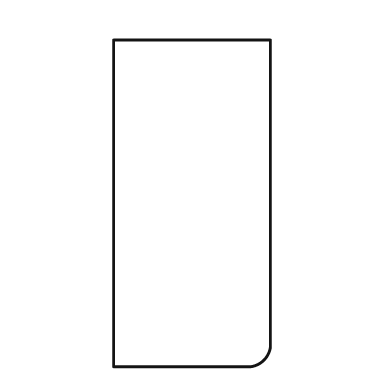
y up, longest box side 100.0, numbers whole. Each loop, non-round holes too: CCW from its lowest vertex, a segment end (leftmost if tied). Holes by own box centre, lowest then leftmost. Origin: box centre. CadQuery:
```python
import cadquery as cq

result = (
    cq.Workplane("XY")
    .moveTo(-24.0, -50.0)
    .lineTo(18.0, -50.0)
    .threePointArc((22.0, -48.0), (24.0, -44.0))
    .lineTo(24.0, 50.0)
    .lineTo(-24.0, 50.0)
    .close()
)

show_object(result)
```